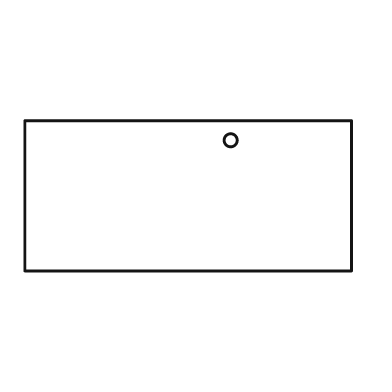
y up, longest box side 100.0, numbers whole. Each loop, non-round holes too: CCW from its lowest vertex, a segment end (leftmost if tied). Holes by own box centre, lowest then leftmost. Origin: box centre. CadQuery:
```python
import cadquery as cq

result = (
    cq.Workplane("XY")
    .moveTo(-50.0, -23.0)
    .lineTo(50.0, -23.0)
    .lineTo(50.0, 23.0)
    .lineTo(-50.0, 23.0)
    .close()
    .moveTo(13.0, 17.0)
    .circle(2.0)
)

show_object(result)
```